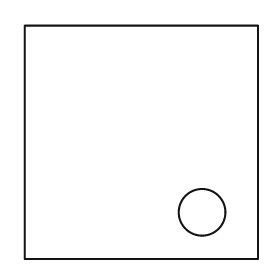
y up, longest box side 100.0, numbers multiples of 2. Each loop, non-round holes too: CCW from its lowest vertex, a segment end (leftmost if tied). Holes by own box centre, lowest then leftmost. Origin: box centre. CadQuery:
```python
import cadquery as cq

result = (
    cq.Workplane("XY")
    .moveTo(-50.0, -50.0)
    .lineTo(50.0, -50.0)
    .lineTo(50.0, 50.0)
    .lineTo(-50.0, 50.0)
    .close()
    .moveTo(26.0, -30.0)
    .circle(10.0)
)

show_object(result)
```